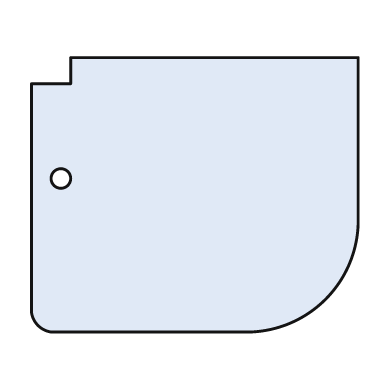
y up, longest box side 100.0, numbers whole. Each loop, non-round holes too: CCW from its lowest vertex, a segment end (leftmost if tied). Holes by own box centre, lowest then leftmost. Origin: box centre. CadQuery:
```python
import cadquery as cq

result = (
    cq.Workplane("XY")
    .moveTo(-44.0, -42.0)
    .lineTo(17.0, -42.0)
    .threePointArc((40.0, -32.0), (50.0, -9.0))
    .lineTo(50.0, 42.0)
    .lineTo(-38.0, 42.0)
    .lineTo(-38.0, 34.0)
    .lineTo(-50.0, 34.0)
    .lineTo(-50.0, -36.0)
    .threePointArc((-48.0, -40.0), (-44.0, -42.0))
    .close()
    .moveTo(-41.0, 5.0)
    .circle(3.0)
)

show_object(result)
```